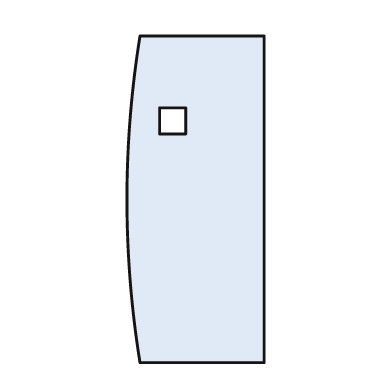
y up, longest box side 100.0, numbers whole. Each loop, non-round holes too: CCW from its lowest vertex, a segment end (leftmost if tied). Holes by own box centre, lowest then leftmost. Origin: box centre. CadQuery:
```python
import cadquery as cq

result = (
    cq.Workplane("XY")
    .moveTo(-17.0, -50.0)
    .lineTo(21.0, -50.0)
    .lineTo(21.0, 50.0)
    .lineTo(-17.0, 50.0)
    .threePointArc((-21.0, 0.0), (-17.0, -50.0))
    .close()
    .moveTo(-11.0, 20.0)
    .lineTo(-3.0, 20.0)
    .lineTo(-3.0, 28.0)
    .lineTo(-11.0, 28.0)
    .close()
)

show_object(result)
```